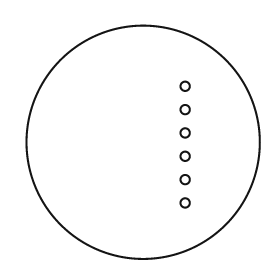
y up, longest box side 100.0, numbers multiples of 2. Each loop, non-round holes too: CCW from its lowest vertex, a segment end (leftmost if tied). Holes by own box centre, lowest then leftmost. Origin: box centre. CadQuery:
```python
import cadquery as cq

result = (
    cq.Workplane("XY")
    .moveTo(0.0, 0.0)
    .circle(50.0)
    .moveTo(18.0, -26.0)
    .circle(2.0)
    .moveTo(18.0, -16.0)
    .circle(2.0)
    .moveTo(18.0, -6.0)
    .circle(2.0)
    .moveTo(18.0, 4.0)
    .circle(2.0)
    .moveTo(18.0, 14.0)
    .circle(2.0)
    .moveTo(18.0, 24.0)
    .circle(2.0)
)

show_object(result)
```